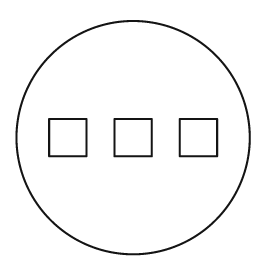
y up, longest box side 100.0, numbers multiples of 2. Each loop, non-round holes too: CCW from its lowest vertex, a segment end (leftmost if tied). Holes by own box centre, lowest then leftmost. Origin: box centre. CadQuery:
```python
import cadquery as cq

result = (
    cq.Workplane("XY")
    .moveTo(0.0, 0.0)
    .circle(50.0)
    .moveTo(-36.0, -8.0)
    .lineTo(-20.0, -8.0)
    .lineTo(-20.0, 8.0)
    .lineTo(-36.0, 8.0)
    .close()
    .moveTo(-8.0, -8.0)
    .lineTo(8.0, -8.0)
    .lineTo(8.0, 8.0)
    .lineTo(-8.0, 8.0)
    .close()
    .moveTo(20.0, -8.0)
    .lineTo(36.0, -8.0)
    .lineTo(36.0, 8.0)
    .lineTo(20.0, 8.0)
    .close()
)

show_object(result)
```